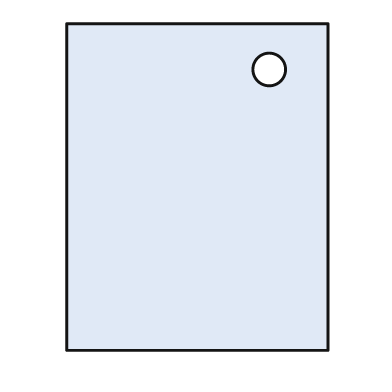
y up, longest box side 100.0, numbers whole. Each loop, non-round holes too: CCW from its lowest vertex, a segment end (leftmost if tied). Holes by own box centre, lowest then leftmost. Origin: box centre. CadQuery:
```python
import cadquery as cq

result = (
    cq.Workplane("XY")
    .moveTo(-40.0, -50.0)
    .lineTo(40.0, -50.0)
    .lineTo(40.0, 50.0)
    .lineTo(-40.0, 50.0)
    .close()
    .moveTo(22.0, 36.0)
    .circle(5.0)
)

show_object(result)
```